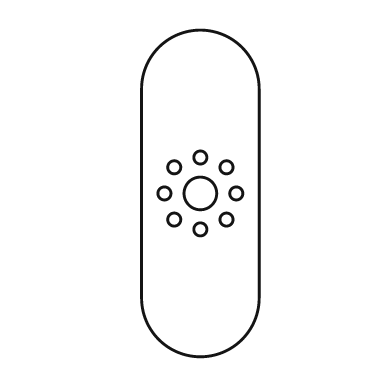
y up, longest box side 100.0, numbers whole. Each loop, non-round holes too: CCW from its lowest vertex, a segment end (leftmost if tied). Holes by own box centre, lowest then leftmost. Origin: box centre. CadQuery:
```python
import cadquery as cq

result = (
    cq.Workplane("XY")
    .moveTo(-18.0, -32.0)
    .threePointArc((0.0, -50.0), (18.0, -32.0))
    .lineTo(18.0, 32.0)
    .threePointArc((0.0, 50.0), (-18.0, 32.0))
    .close()
    .moveTo(0.0, -11.0)
    .circle(2.0)
    .moveTo(-8.0, -8.0)
    .circle(2.0)
    .moveTo(8.0, -8.0)
    .circle(2.0)
    .moveTo(-11.0, 0.0)
    .circle(2.0)
    .moveTo(0.0, 0.0)
    .circle(5.0)
    .moveTo(11.0, 0.0)
    .circle(2.0)
    .moveTo(-8.0, 8.0)
    .circle(2.0)
    .moveTo(8.0, 8.0)
    .circle(2.0)
    .moveTo(0.0, 11.0)
    .circle(2.0)
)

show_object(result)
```